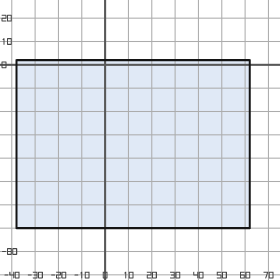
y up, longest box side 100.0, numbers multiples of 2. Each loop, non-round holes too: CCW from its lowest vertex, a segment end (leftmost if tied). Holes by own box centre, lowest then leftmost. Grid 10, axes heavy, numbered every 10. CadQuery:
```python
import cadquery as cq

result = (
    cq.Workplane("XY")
    .moveTo(-38.0, -70.0)
    .lineTo(62.0, -70.0)
    .lineTo(62.0, 2.0)
    .lineTo(-38.0, 2.0)
    .close()
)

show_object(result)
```